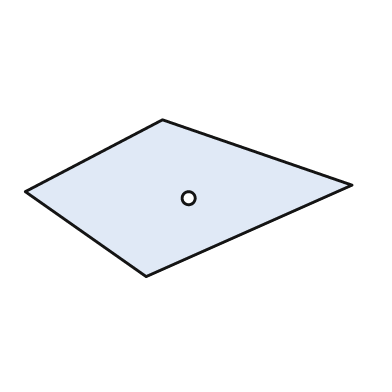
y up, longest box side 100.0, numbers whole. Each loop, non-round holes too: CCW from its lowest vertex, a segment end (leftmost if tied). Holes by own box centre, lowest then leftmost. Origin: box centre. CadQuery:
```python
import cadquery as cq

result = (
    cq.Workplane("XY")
    .moveTo(-13.0, -24.0)
    .lineTo(50.0, 4.0)
    .lineTo(-8.0, 24.0)
    .lineTo(-50.0, 2.0)
    .close()
    .moveTo(0.0, 0.0)
    .circle(2.0)
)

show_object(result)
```